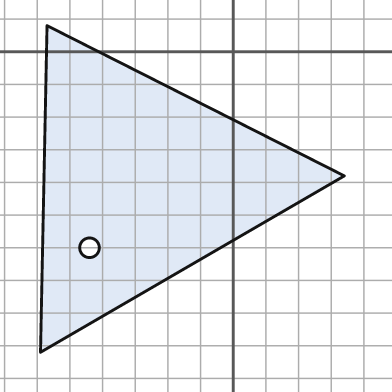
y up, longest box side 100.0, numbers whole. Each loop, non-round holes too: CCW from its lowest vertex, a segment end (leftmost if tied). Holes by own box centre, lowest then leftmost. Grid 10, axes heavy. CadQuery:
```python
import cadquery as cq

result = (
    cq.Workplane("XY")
    .moveTo(-59.0, -92.0)
    .lineTo(34.0, -38.0)
    .lineTo(-57.0, 8.0)
    .close()
    .moveTo(-44.0, -60.0)
    .circle(3.0)
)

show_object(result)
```